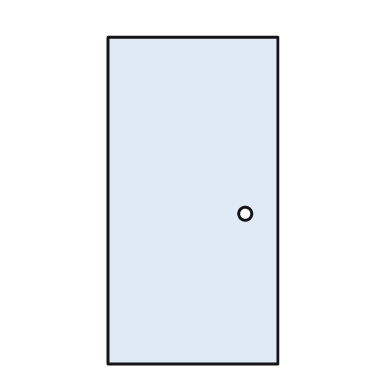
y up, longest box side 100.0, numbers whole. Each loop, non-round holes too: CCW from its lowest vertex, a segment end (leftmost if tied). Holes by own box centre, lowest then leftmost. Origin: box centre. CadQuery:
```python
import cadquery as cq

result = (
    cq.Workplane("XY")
    .moveTo(-26.0, -50.0)
    .lineTo(26.0, -50.0)
    .lineTo(26.0, 50.0)
    .lineTo(-26.0, 50.0)
    .close()
    .moveTo(16.0, -4.0)
    .circle(2.0)
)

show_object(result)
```